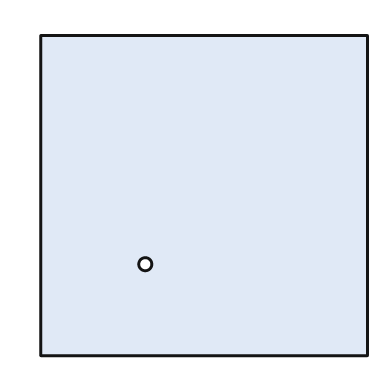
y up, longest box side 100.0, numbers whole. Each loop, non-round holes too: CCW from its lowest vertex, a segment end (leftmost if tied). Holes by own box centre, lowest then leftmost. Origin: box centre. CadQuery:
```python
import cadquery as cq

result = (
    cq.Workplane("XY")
    .moveTo(-50.0, -49.0)
    .lineTo(50.0, -49.0)
    .lineTo(50.0, 49.0)
    .lineTo(-50.0, 49.0)
    .close()
    .moveTo(-18.0, -21.0)
    .circle(2.0)
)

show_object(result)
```